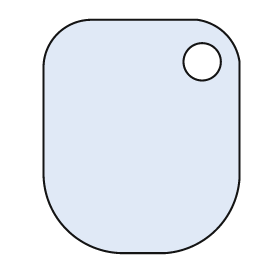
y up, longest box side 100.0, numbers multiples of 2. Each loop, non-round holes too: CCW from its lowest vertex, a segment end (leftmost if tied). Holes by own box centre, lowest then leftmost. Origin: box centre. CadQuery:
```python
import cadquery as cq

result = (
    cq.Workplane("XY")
    .moveTo(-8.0, -50.0)
    .lineTo(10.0, -50.0)
    .threePointArc((32.0, -40.0), (42.0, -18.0))
    .lineTo(42.0, 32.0)
    .threePointArc((36.0, 44.0), (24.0, 50.0))
    .lineTo(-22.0, 50.0)
    .threePointArc((-36.0, 44.0), (-42.0, 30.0))
    .lineTo(-42.0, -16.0)
    .threePointArc((-32.0, -40.0), (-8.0, -50.0))
    .close()
    .moveTo(26.0, 32.0)
    .circle(8.0)
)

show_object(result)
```